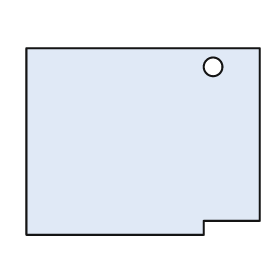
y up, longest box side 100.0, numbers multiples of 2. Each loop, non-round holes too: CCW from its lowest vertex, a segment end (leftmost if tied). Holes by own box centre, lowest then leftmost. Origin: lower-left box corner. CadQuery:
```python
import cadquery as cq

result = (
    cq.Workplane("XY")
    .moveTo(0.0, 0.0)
    .lineTo(76.0, 0.0)
    .lineTo(76.0, 6.0)
    .lineTo(100.0, 6.0)
    .lineTo(100.0, 80.0)
    .lineTo(0.0, 80.0)
    .close()
    .moveTo(80.0, 72.0)
    .circle(4.0)
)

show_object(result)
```